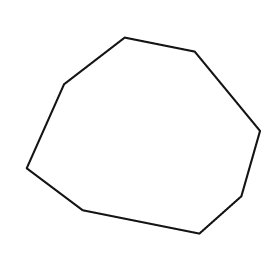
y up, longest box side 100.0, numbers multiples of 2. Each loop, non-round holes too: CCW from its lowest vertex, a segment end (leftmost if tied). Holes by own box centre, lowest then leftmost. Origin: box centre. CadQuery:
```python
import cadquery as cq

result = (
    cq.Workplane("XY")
    .moveTo(24.0, -42.0)
    .lineTo(42.0, -26.0)
    .lineTo(50.0, 2.0)
    .lineTo(22.0, 36.0)
    .lineTo(-8.0, 42.0)
    .lineTo(-34.0, 22.0)
    .lineTo(-50.0, -14.0)
    .lineTo(-26.0, -32.0)
    .close()
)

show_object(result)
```